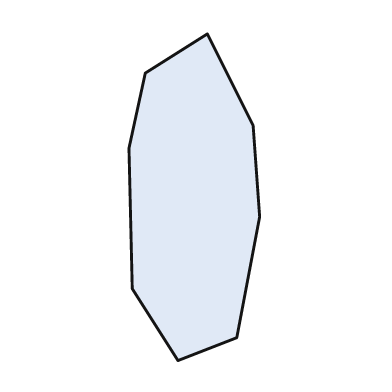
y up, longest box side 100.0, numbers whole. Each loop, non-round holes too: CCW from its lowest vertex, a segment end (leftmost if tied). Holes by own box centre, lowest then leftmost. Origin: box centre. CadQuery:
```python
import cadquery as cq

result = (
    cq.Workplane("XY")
    .moveTo(-5.0, -50.0)
    .lineTo(13.0, -43.0)
    .lineTo(20.0, -6.0)
    .lineTo(18.0, 22.0)
    .lineTo(4.0, 50.0)
    .lineTo(-15.0, 38.0)
    .lineTo(-20.0, 15.0)
    .lineTo(-19.0, -28.0)
    .close()
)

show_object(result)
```